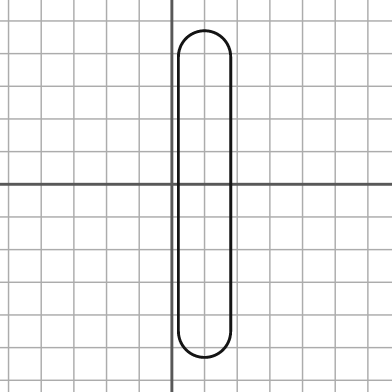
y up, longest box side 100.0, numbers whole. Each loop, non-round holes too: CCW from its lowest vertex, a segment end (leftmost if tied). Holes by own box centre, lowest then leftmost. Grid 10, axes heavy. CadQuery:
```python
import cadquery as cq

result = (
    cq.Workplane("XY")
    .moveTo(2.0, -45.0)
    .threePointArc((10.0, -53.0), (18.0, -45.0))
    .lineTo(18.0, 39.0)
    .threePointArc((10.0, 47.0), (2.0, 39.0))
    .close()
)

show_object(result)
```